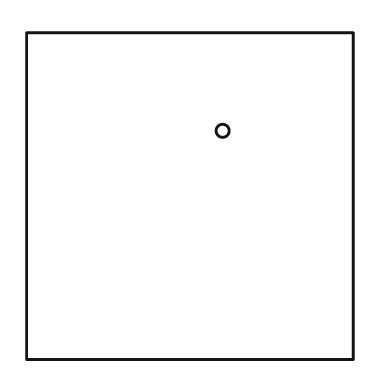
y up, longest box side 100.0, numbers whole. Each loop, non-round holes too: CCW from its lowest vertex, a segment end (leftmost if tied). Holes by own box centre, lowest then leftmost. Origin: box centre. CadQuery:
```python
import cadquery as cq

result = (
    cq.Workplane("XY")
    .moveTo(-50.0, -50.0)
    .lineTo(50.0, -50.0)
    .lineTo(50.0, 50.0)
    .lineTo(-50.0, 50.0)
    .close()
    .moveTo(10.0, 20.0)
    .circle(2.0)
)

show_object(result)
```